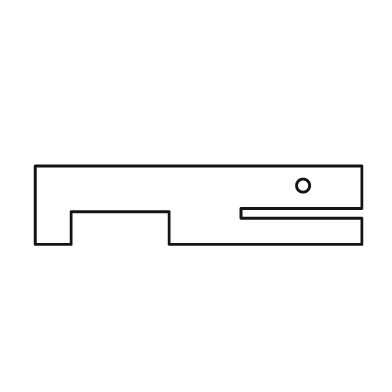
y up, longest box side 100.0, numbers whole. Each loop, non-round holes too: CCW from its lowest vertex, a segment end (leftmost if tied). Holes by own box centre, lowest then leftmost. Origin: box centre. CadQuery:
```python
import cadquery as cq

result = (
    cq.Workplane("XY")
    .moveTo(-50.0, -12.0)
    .lineTo(-39.0, -12.0)
    .lineTo(-39.0, -2.0)
    .lineTo(-9.0, -2.0)
    .lineTo(-9.0, -12.0)
    .lineTo(50.0, -12.0)
    .lineTo(50.0, -4.0)
    .lineTo(13.0, -4.0)
    .lineTo(13.0, -1.0)
    .lineTo(50.0, -1.0)
    .lineTo(50.0, 12.0)
    .lineTo(-50.0, 12.0)
    .close()
    .moveTo(32.0, 6.0)
    .circle(2.0)
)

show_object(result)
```